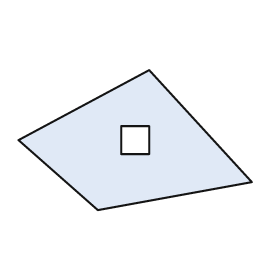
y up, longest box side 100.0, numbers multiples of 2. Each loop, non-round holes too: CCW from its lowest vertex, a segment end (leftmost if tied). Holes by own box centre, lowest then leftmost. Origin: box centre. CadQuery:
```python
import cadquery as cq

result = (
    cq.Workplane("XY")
    .moveTo(-16.0, -30.0)
    .lineTo(50.0, -18.0)
    .lineTo(6.0, 30.0)
    .lineTo(-50.0, 0.0)
    .close()
    .moveTo(-6.0, -6.0)
    .lineTo(6.0, -6.0)
    .lineTo(6.0, 6.0)
    .lineTo(-6.0, 6.0)
    .close()
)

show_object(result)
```